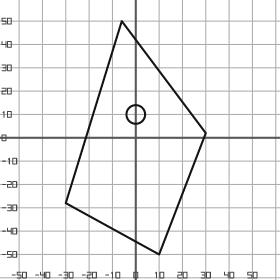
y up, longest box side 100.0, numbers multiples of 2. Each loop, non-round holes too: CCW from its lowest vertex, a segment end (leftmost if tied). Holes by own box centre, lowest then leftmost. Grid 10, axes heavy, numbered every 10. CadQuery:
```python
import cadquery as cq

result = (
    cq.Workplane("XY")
    .moveTo(10.0, -50.0)
    .lineTo(30.0, 2.0)
    .lineTo(-6.0, 50.0)
    .lineTo(-30.0, -28.0)
    .close()
    .moveTo(0.0, 10.0)
    .circle(4.0)
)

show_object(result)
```